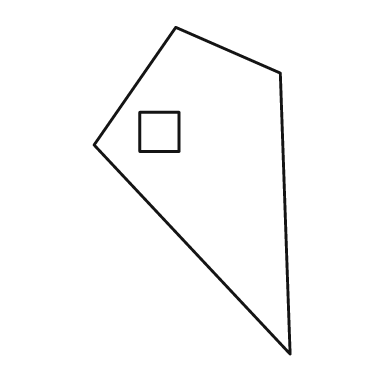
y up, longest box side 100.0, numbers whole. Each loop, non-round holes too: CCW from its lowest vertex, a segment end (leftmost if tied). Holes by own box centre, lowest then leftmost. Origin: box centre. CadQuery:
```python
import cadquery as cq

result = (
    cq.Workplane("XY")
    .moveTo(30.0, -50.0)
    .lineTo(27.0, 36.0)
    .lineTo(-5.0, 50.0)
    .lineTo(-30.0, 14.0)
    .close()
    .moveTo(-16.0, 12.0)
    .lineTo(-4.0, 12.0)
    .lineTo(-4.0, 24.0)
    .lineTo(-16.0, 24.0)
    .close()
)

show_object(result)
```